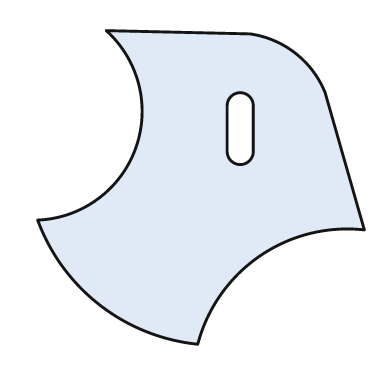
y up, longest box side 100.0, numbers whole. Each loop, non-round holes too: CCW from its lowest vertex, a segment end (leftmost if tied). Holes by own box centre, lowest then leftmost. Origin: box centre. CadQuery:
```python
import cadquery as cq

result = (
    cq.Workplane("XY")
    .moveTo(-1.0, -48.0)
    .threePointArc((18.0, -21.0), (50.0, -13.0))
    .lineTo(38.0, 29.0)
    .threePointArc((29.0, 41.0), (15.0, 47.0))
    .lineTo(-29.0, 48.0)
    .threePointArc((-20.0, 12.0), (-50.0, -10.0))
    .threePointArc((-31.0, -36.0), (-1.0, -48.0))
    .close()
    .moveTo(8.0, 11.0)
    .threePointArc((12.0, 7.0), (16.0, 11.0))
    .lineTo(16.0, 25.0)
    .threePointArc((12.0, 29.0), (8.0, 25.0))
    .close()
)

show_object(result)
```